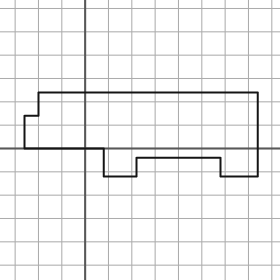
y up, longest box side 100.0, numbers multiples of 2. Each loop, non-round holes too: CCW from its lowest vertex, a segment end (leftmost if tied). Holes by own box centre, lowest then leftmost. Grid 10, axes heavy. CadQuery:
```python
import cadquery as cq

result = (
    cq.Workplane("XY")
    .moveTo(8.0, -12.0)
    .lineTo(22.0, -12.0)
    .lineTo(22.0, -4.0)
    .lineTo(58.0, -4.0)
    .lineTo(58.0, -12.0)
    .lineTo(74.0, -12.0)
    .lineTo(74.0, 24.0)
    .lineTo(-20.0, 24.0)
    .lineTo(-20.0, 14.0)
    .lineTo(-26.0, 14.0)
    .lineTo(-26.0, 0.0)
    .lineTo(8.0, 0.0)
    .close()
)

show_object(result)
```